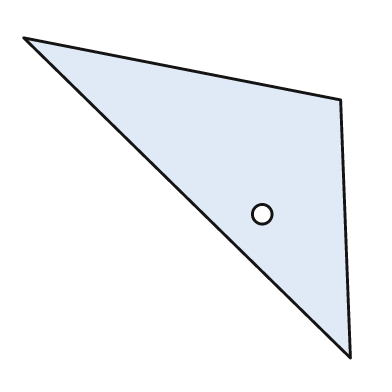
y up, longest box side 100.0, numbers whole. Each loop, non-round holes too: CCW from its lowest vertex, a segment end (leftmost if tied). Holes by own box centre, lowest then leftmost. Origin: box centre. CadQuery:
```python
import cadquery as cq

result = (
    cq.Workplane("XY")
    .moveTo(50.0, -49.0)
    .lineTo(47.0, 30.0)
    .lineTo(-50.0, 49.0)
    .close()
    .moveTo(23.0, -5.0)
    .circle(3.0)
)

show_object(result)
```